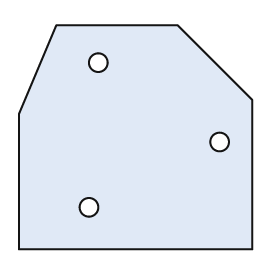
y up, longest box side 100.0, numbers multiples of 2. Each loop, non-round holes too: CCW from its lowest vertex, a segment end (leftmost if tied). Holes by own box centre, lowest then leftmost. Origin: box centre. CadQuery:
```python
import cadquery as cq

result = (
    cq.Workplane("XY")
    .moveTo(-50.0, -48.0)
    .lineTo(50.0, -48.0)
    .lineTo(50.0, 16.0)
    .lineTo(18.0, 48.0)
    .lineTo(-34.0, 48.0)
    .lineTo(-50.0, 10.0)
    .close()
    .moveTo(-20.0, -30.0)
    .circle(4.0)
    .moveTo(36.0, -2.0)
    .circle(4.0)
    .moveTo(-16.0, 32.0)
    .circle(4.0)
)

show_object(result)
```